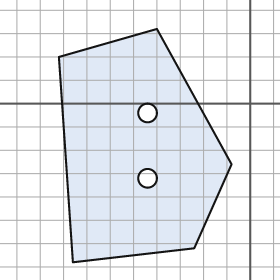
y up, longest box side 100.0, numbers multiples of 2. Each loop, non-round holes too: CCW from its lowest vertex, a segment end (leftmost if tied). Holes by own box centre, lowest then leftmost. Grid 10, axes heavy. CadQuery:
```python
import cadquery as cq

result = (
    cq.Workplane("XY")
    .moveTo(-76.0, -68.0)
    .lineTo(-24.0, -62.0)
    .lineTo(-8.0, -26.0)
    .lineTo(-40.0, 32.0)
    .lineTo(-82.0, 20.0)
    .close()
    .moveTo(-44.0, -32.0)
    .circle(4.0)
    .moveTo(-44.0, -4.0)
    .circle(4.0)
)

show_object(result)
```